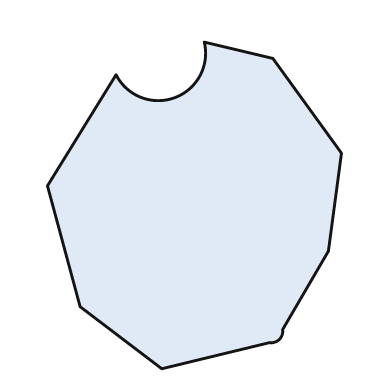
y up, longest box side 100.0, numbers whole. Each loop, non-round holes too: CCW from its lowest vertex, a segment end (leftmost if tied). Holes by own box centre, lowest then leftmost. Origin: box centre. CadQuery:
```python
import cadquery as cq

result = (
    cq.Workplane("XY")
    .moveTo(-10.0, -50.0)
    .lineTo(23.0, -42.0)
    .threePointArc((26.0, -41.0), (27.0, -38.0))
    .lineTo(41.0, -14.0)
    .lineTo(45.0, 16.0)
    .lineTo(24.0, 45.0)
    .lineTo(3.0, 50.0)
    .threePointArc((-6.0, 33.0), (-24.0, 40.0))
    .lineTo(-45.0, 6.0)
    .lineTo(-35.0, -31.0)
    .close()
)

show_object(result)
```